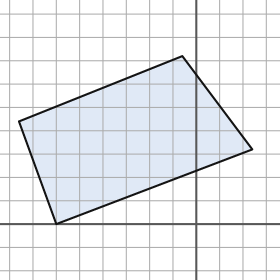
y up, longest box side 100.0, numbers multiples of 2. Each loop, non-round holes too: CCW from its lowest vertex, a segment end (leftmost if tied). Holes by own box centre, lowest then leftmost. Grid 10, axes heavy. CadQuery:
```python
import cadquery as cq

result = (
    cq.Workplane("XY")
    .moveTo(-60.0, 0.0)
    .lineTo(24.0, 32.0)
    .lineTo(-6.0, 72.0)
    .lineTo(-76.0, 44.0)
    .close()
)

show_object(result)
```